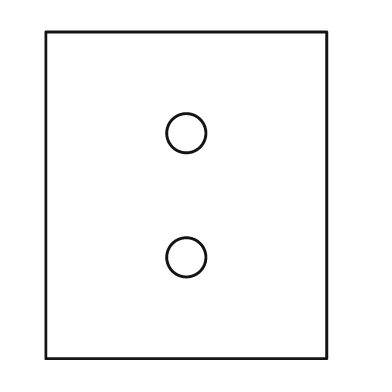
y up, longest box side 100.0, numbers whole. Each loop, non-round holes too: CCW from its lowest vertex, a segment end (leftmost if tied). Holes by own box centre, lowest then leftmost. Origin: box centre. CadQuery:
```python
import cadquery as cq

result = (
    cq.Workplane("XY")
    .moveTo(-43.0, -50.0)
    .lineTo(43.0, -50.0)
    .lineTo(43.0, 50.0)
    .lineTo(-43.0, 50.0)
    .close()
    .moveTo(0.0, -19.0)
    .circle(6.0)
    .moveTo(0.0, 19.0)
    .circle(6.0)
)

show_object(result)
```